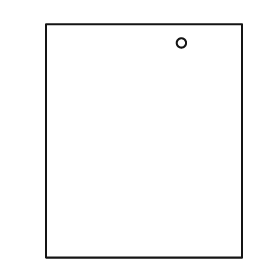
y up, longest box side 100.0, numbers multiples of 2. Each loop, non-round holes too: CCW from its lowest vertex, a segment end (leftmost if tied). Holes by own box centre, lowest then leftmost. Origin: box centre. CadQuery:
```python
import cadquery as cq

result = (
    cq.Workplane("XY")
    .moveTo(-42.0, -50.0)
    .lineTo(42.0, -50.0)
    .lineTo(42.0, 50.0)
    .lineTo(-42.0, 50.0)
    .close()
    .moveTo(16.0, 42.0)
    .circle(2.0)
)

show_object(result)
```